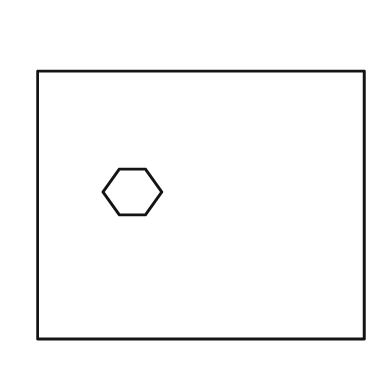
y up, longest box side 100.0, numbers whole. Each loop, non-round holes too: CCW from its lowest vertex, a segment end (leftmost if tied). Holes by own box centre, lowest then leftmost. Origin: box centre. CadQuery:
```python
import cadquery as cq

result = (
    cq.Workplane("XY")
    .moveTo(-50.0, -41.0)
    .lineTo(50.0, -41.0)
    .lineTo(50.0, 41.0)
    .lineTo(-50.0, 41.0)
    .close()
    .moveTo(-25.0, -3.0)
    .lineTo(-17.0, -3.0)
    .lineTo(-12.0, 4.0)
    .lineTo(-17.0, 11.0)
    .lineTo(-25.0, 11.0)
    .lineTo(-30.0, 4.0)
    .close()
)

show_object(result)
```